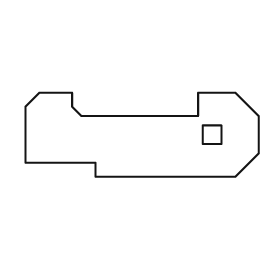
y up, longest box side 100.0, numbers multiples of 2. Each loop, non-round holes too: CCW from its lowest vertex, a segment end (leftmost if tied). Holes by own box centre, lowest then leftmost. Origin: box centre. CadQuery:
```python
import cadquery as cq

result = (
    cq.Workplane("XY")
    .moveTo(-20.0, -18.0)
    .lineTo(40.0, -18.0)
    .lineTo(50.0, -8.0)
    .lineTo(50.0, 8.0)
    .lineTo(40.0, 18.0)
    .lineTo(24.0, 18.0)
    .lineTo(24.0, 8.0)
    .lineTo(-26.0, 8.0)
    .lineTo(-30.0, 12.0)
    .lineTo(-30.0, 18.0)
    .lineTo(-44.0, 18.0)
    .lineTo(-50.0, 12.0)
    .lineTo(-50.0, -12.0)
    .lineTo(-20.0, -12.0)
    .close()
    .moveTo(26.0, -4.0)
    .lineTo(34.0, -4.0)
    .lineTo(34.0, 4.0)
    .lineTo(26.0, 4.0)
    .close()
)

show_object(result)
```